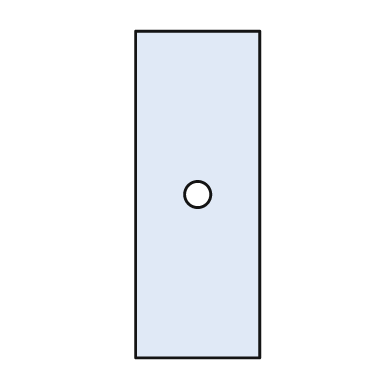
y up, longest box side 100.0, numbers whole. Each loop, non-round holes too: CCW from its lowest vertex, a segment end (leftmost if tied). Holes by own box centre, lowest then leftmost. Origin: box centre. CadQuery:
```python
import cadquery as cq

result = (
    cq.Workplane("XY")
    .moveTo(-19.0, -50.0)
    .lineTo(19.0, -50.0)
    .lineTo(19.0, 50.0)
    .lineTo(-19.0, 50.0)
    .close()
    .moveTo(0.0, 0.0)
    .circle(4.0)
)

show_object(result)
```